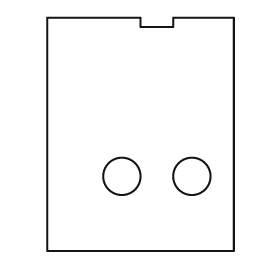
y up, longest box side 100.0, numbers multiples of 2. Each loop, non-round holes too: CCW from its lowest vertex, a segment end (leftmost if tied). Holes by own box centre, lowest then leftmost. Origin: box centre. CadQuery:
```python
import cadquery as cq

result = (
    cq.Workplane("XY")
    .moveTo(-40.0, -50.0)
    .lineTo(40.0, -50.0)
    .lineTo(40.0, 50.0)
    .lineTo(14.0, 50.0)
    .lineTo(14.0, 46.0)
    .lineTo(0.0, 46.0)
    .lineTo(0.0, 50.0)
    .lineTo(-40.0, 50.0)
    .close()
    .moveTo(-8.0, -18.0)
    .circle(8.0)
    .moveTo(22.0, -18.0)
    .circle(8.0)
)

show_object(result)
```